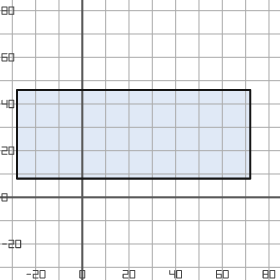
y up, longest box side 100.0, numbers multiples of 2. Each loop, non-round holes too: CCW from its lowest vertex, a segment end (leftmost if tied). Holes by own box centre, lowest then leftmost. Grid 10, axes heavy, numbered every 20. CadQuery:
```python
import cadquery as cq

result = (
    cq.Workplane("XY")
    .moveTo(-28.0, 8.0)
    .lineTo(72.0, 8.0)
    .lineTo(72.0, 46.0)
    .lineTo(-28.0, 46.0)
    .close()
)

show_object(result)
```